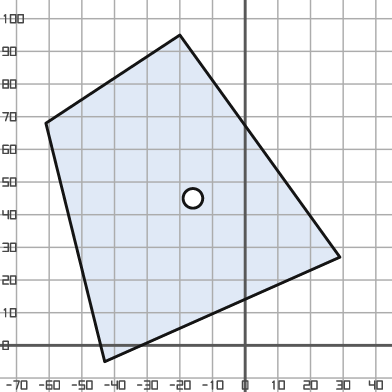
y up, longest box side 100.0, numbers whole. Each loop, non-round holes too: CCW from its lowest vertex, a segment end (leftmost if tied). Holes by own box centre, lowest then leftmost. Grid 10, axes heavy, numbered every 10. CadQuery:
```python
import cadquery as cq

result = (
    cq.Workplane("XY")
    .moveTo(-43.0, -5.0)
    .lineTo(29.0, 27.0)
    .lineTo(-20.0, 95.0)
    .lineTo(-61.0, 68.0)
    .close()
    .moveTo(-16.0, 45.0)
    .circle(3.0)
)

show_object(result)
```